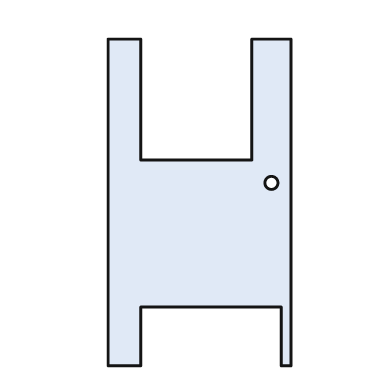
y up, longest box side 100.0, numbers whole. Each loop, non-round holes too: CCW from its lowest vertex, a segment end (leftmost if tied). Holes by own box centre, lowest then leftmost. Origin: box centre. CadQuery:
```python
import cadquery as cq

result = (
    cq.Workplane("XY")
    .moveTo(-28.0, -50.0)
    .lineTo(-18.0, -50.0)
    .lineTo(-18.0, -32.0)
    .lineTo(25.0, -32.0)
    .lineTo(25.0, -50.0)
    .lineTo(28.0, -50.0)
    .lineTo(28.0, 50.0)
    .lineTo(16.0, 50.0)
    .lineTo(16.0, 13.0)
    .lineTo(-18.0, 13.0)
    .lineTo(-18.0, 50.0)
    .lineTo(-28.0, 50.0)
    .close()
    .moveTo(22.0, 6.0)
    .circle(2.0)
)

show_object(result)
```